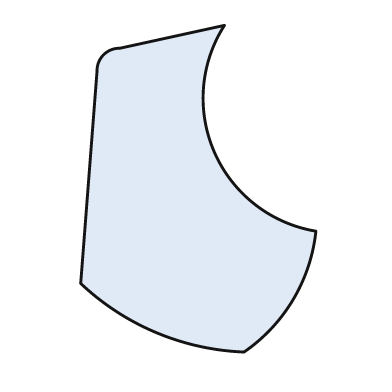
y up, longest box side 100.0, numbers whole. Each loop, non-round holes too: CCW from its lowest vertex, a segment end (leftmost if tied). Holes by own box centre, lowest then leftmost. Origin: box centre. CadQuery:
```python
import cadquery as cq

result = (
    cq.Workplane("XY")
    .moveTo(14.0, -50.0)
    .threePointArc((29.0, -34.0), (36.0, -13.0))
    .threePointArc((5.0, 11.0), (8.0, 50.0))
    .lineTo(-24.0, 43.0)
    .threePointArc((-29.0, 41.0), (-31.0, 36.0))
    .lineTo(-36.0, -29.0)
    .threePointArc((-13.0, -44.0), (14.0, -50.0))
    .close()
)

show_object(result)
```